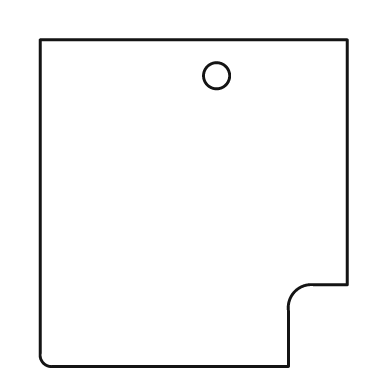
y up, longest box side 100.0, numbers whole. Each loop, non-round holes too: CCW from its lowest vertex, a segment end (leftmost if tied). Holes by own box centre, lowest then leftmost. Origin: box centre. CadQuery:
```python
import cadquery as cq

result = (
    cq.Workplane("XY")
    .moveTo(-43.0, -50.0)
    .lineTo(29.0, -50.0)
    .lineTo(29.0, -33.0)
    .threePointArc((31.0, -27.0), (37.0, -25.0))
    .lineTo(47.0, -25.0)
    .lineTo(47.0, 50.0)
    .lineTo(-47.0, 50.0)
    .lineTo(-47.0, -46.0)
    .threePointArc((-46.0, -49.0), (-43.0, -50.0))
    .close()
    .moveTo(7.0, 39.0)
    .circle(4.0)
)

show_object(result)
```